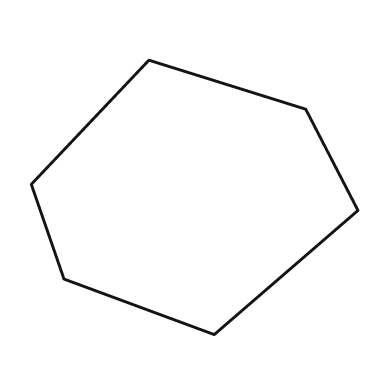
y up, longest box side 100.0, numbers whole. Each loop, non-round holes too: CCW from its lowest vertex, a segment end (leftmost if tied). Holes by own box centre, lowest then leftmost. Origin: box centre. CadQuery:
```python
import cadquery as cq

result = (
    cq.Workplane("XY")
    .moveTo(6.0, -42.0)
    .lineTo(50.0, -4.0)
    .lineTo(34.0, 27.0)
    .lineTo(-14.0, 42.0)
    .lineTo(-50.0, 4.0)
    .lineTo(-40.0, -25.0)
    .close()
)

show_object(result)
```